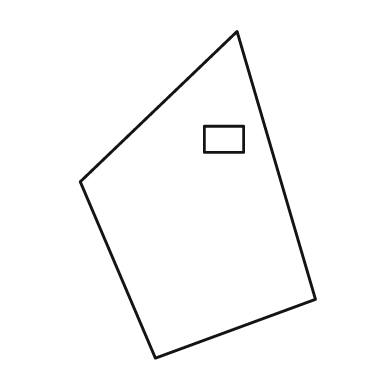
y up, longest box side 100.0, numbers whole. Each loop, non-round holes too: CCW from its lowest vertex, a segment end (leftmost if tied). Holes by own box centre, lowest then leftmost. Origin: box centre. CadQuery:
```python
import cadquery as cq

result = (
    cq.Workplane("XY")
    .moveTo(-13.0, -50.0)
    .lineTo(36.0, -32.0)
    .lineTo(12.0, 50.0)
    .lineTo(-36.0, 4.0)
    .close()
    .moveTo(2.0, 13.0)
    .lineTo(14.0, 13.0)
    .lineTo(14.0, 21.0)
    .lineTo(2.0, 21.0)
    .close()
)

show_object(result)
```